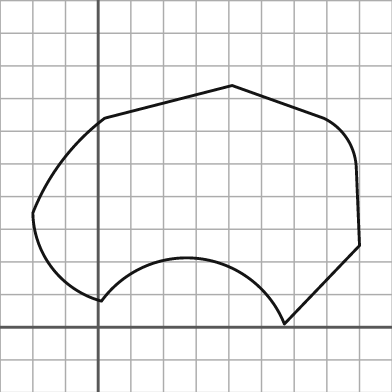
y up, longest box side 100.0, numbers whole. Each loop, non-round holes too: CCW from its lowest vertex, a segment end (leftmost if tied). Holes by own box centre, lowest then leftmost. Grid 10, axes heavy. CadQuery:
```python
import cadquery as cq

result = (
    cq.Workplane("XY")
    .moveTo(57.0, 1.0)
    .lineTo(80.0, 25.0)
    .lineTo(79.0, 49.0)
    .threePointArc((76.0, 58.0), (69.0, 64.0))
    .lineTo(41.0, 74.0)
    .lineTo(2.0, 64.0)
    .threePointArc((-11.0, 51.0), (-20.0, 35.0))
    .threePointArc((-14.0, 18.0), (1.0, 8.0))
    .threePointArc((31.0, 21.0), (57.0, 1.0))
    .close()
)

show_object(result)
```